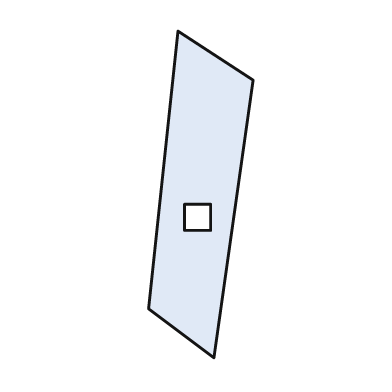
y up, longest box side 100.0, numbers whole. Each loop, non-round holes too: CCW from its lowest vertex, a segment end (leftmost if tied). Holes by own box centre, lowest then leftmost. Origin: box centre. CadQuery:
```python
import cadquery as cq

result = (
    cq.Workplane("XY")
    .moveTo(4.0, -50.0)
    .lineTo(16.0, 35.0)
    .lineTo(-7.0, 50.0)
    .lineTo(-16.0, -35.0)
    .close()
    .moveTo(-5.0, -11.0)
    .lineTo(3.0, -11.0)
    .lineTo(3.0, -3.0)
    .lineTo(-5.0, -3.0)
    .close()
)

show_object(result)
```